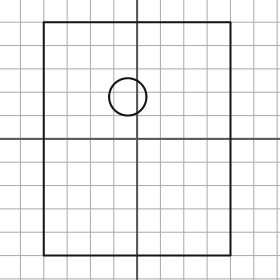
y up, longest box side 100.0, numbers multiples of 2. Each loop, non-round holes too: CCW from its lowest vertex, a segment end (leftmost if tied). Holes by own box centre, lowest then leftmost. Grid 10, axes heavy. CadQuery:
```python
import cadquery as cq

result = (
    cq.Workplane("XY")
    .moveTo(-40.0, -50.0)
    .lineTo(40.0, -50.0)
    .lineTo(40.0, 50.0)
    .lineTo(-40.0, 50.0)
    .close()
    .moveTo(-4.0, 18.0)
    .circle(8.0)
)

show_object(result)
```